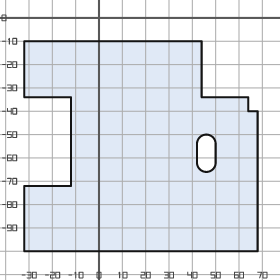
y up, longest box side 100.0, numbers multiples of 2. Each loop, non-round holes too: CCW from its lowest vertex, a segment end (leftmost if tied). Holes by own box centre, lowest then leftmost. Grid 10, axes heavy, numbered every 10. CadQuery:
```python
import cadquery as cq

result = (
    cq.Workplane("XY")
    .moveTo(-32.0, -100.0)
    .lineTo(68.0, -100.0)
    .lineTo(68.0, -40.0)
    .lineTo(64.0, -40.0)
    .lineTo(64.0, -34.0)
    .lineTo(44.0, -34.0)
    .lineTo(44.0, -10.0)
    .lineTo(-32.0, -10.0)
    .lineTo(-32.0, -34.0)
    .lineTo(-12.0, -34.0)
    .lineTo(-12.0, -72.0)
    .lineTo(-32.0, -72.0)
    .close()
    .moveTo(42.0, -62.0)
    .threePointArc((46.0, -66.0), (50.0, -62.0))
    .lineTo(50.0, -54.0)
    .threePointArc((46.0, -50.0), (42.0, -54.0))
    .close()
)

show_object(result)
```